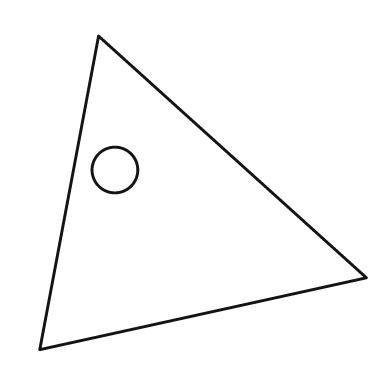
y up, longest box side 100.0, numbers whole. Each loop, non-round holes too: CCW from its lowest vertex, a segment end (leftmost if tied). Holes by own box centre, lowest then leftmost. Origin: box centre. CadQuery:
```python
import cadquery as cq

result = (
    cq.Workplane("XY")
    .moveTo(-50.0, -48.0)
    .lineTo(50.0, -26.0)
    .lineTo(-32.0, 48.0)
    .close()
    .moveTo(-27.0, 7.0)
    .circle(7.0)
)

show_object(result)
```